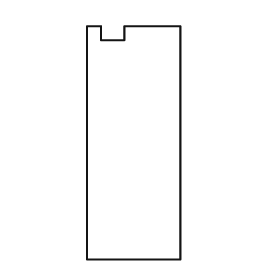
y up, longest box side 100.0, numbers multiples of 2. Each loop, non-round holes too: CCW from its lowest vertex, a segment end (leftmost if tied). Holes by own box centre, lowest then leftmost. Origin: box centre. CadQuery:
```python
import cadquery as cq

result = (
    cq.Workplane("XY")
    .moveTo(-20.0, -50.0)
    .lineTo(20.0, -50.0)
    .lineTo(20.0, 50.0)
    .lineTo(-4.0, 50.0)
    .lineTo(-4.0, 44.0)
    .lineTo(-14.0, 44.0)
    .lineTo(-14.0, 50.0)
    .lineTo(-20.0, 50.0)
    .close()
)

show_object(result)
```